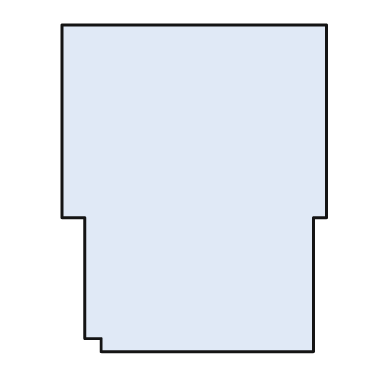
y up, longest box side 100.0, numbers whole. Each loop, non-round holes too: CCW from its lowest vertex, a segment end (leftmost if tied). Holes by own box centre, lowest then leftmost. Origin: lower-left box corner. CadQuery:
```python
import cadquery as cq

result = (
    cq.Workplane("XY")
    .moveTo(12.0, 0.0)
    .lineTo(77.0, 0.0)
    .lineTo(77.0, 41.0)
    .lineTo(81.0, 41.0)
    .lineTo(81.0, 100.0)
    .lineTo(0.0, 100.0)
    .lineTo(0.0, 41.0)
    .lineTo(7.0, 41.0)
    .lineTo(7.0, 4.0)
    .lineTo(12.0, 4.0)
    .close()
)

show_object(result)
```